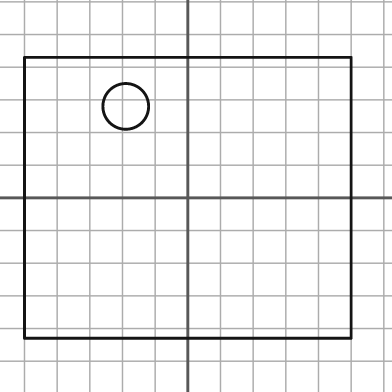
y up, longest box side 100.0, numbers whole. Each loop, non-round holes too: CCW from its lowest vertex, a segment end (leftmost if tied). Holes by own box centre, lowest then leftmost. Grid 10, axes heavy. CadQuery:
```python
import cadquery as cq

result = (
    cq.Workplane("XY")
    .moveTo(-50.0, -43.0)
    .lineTo(50.0, -43.0)
    .lineTo(50.0, 43.0)
    .lineTo(-50.0, 43.0)
    .close()
    .moveTo(-19.0, 28.0)
    .circle(7.0)
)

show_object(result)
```